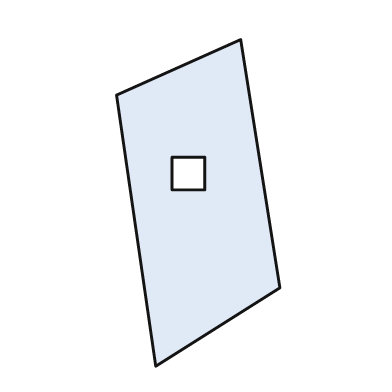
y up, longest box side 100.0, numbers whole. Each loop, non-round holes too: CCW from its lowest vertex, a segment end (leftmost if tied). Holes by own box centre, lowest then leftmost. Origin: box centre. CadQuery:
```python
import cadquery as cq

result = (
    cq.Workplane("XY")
    .moveTo(-13.0, -50.0)
    .lineTo(25.0, -26.0)
    .lineTo(13.0, 50.0)
    .lineTo(-25.0, 33.0)
    .close()
    .moveTo(-8.0, 4.0)
    .lineTo(2.0, 4.0)
    .lineTo(2.0, 14.0)
    .lineTo(-8.0, 14.0)
    .close()
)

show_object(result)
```